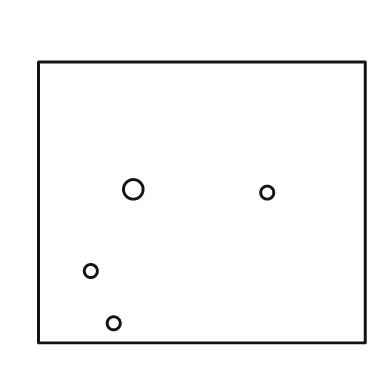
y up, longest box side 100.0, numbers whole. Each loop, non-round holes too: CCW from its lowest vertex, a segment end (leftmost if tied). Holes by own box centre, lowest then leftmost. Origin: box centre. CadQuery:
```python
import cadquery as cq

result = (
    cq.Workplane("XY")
    .moveTo(-50.0, -43.0)
    .lineTo(50.0, -43.0)
    .lineTo(50.0, 43.0)
    .lineTo(-50.0, 43.0)
    .close()
    .moveTo(-27.0, -37.0)
    .circle(2.0)
    .moveTo(-34.0, -21.0)
    .circle(2.0)
    .moveTo(20.0, 3.0)
    .circle(2.0)
    .moveTo(-21.0, 4.0)
    .circle(3.0)
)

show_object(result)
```